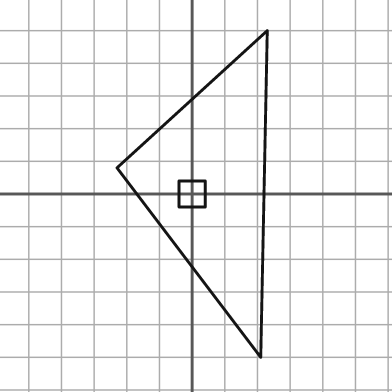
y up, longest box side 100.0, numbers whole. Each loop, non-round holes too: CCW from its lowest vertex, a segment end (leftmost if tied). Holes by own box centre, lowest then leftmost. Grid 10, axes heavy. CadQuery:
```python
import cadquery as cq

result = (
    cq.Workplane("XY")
    .moveTo(21.0, -50.0)
    .lineTo(23.0, 50.0)
    .lineTo(-23.0, 8.0)
    .close()
    .moveTo(-4.0, -4.0)
    .lineTo(4.0, -4.0)
    .lineTo(4.0, 4.0)
    .lineTo(-4.0, 4.0)
    .close()
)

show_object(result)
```